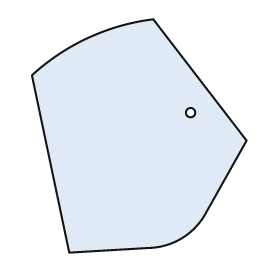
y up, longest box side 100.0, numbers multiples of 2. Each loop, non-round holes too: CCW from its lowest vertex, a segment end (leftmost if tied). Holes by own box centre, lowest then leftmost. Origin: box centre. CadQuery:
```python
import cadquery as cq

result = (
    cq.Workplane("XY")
    .moveTo(-30.0, -50.0)
    .lineTo(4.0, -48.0)
    .threePointArc((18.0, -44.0), (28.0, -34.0))
    .lineTo(46.0, -2.0)
    .lineTo(6.0, 50.0)
    .threePointArc((-22.0, 42.0), (-46.0, 26.0))
    .close()
    .moveTo(22.0, 10.0)
    .circle(2.0)
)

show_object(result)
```